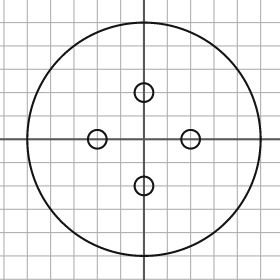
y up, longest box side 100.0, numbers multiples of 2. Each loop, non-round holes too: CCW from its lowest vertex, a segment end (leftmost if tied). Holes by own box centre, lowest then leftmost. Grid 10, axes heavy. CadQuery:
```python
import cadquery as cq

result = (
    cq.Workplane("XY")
    .moveTo(0.0, 0.0)
    .circle(50.0)
    .moveTo(0.0, -20.0)
    .circle(4.0)
    .moveTo(-20.0, 0.0)
    .circle(4.0)
    .moveTo(20.0, 0.0)
    .circle(4.0)
    .moveTo(0.0, 20.0)
    .circle(4.0)
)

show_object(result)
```